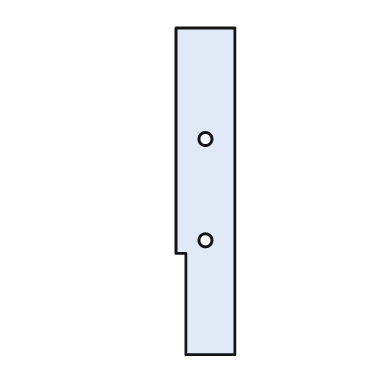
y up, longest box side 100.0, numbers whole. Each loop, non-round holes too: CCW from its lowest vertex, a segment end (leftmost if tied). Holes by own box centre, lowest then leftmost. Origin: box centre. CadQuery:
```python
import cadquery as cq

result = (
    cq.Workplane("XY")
    .moveTo(-6.0, -50.0)
    .lineTo(9.0, -50.0)
    .lineTo(9.0, 50.0)
    .lineTo(-9.0, 50.0)
    .lineTo(-9.0, -19.0)
    .lineTo(-6.0, -19.0)
    .close()
    .moveTo(0.0, -15.0)
    .circle(2.0)
    .moveTo(0.0, 16.0)
    .circle(2.0)
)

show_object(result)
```